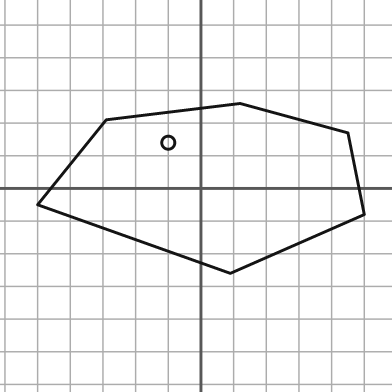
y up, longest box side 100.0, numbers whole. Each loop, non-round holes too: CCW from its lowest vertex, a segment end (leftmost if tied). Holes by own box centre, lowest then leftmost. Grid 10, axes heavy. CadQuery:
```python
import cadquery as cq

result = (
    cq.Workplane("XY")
    .moveTo(9.0, -26.0)
    .lineTo(50.0, -8.0)
    .lineTo(45.0, 17.0)
    .lineTo(12.0, 26.0)
    .lineTo(-29.0, 21.0)
    .lineTo(-50.0, -5.0)
    .close()
    .moveTo(-10.0, 14.0)
    .circle(2.0)
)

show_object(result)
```